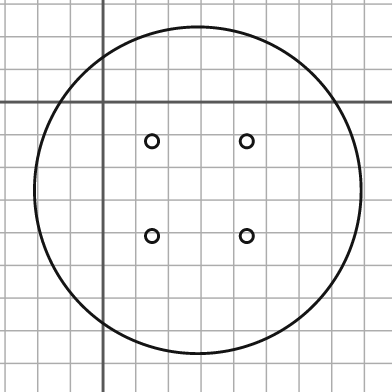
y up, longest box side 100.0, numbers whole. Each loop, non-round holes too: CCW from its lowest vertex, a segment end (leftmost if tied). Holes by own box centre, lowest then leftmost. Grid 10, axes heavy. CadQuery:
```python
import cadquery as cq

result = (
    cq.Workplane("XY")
    .moveTo(29.0, -27.0)
    .circle(50.0)
    .moveTo(15.0, -41.0)
    .circle(2.0)
    .moveTo(44.0, -41.0)
    .circle(2.0)
    .moveTo(15.0, -12.0)
    .circle(2.0)
    .moveTo(44.0, -12.0)
    .circle(2.0)
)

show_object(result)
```